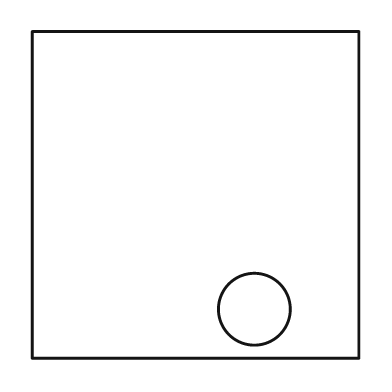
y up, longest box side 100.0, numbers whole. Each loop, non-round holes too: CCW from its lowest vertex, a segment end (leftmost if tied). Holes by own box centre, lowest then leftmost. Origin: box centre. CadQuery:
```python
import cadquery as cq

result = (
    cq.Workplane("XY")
    .moveTo(-50.0, -50.0)
    .lineTo(50.0, -50.0)
    .lineTo(50.0, 50.0)
    .lineTo(-50.0, 50.0)
    .close()
    .moveTo(18.0, -35.0)
    .circle(11.0)
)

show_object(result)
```